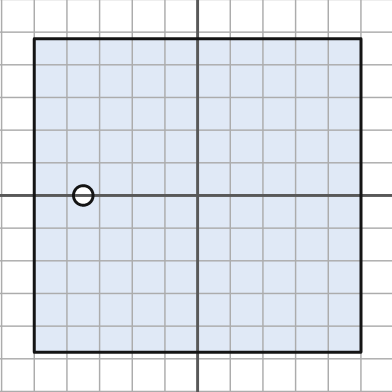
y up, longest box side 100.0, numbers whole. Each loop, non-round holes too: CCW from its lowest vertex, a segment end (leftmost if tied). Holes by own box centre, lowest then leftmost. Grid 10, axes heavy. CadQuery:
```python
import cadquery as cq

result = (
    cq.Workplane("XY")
    .moveTo(-50.0, -48.0)
    .lineTo(50.0, -48.0)
    .lineTo(50.0, 48.0)
    .lineTo(-50.0, 48.0)
    .close()
    .moveTo(-35.0, 0.0)
    .circle(3.0)
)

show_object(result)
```